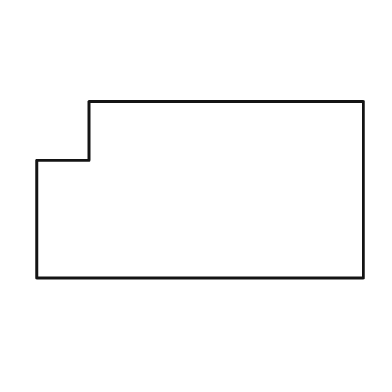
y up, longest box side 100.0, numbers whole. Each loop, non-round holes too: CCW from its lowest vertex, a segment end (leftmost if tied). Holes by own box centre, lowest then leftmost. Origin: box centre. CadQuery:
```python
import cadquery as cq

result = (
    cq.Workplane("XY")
    .moveTo(-50.0, -27.0)
    .lineTo(50.0, -27.0)
    .lineTo(50.0, 27.0)
    .lineTo(-34.0, 27.0)
    .lineTo(-34.0, 9.0)
    .lineTo(-50.0, 9.0)
    .close()
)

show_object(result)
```